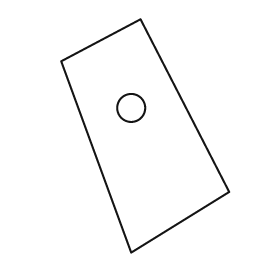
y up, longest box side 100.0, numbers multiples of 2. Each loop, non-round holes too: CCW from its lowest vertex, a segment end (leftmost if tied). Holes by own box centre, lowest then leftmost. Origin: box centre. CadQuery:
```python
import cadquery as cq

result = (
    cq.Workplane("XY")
    .moveTo(-6.0, -50.0)
    .lineTo(36.0, -24.0)
    .lineTo(-2.0, 50.0)
    .lineTo(-36.0, 32.0)
    .close()
    .moveTo(-6.0, 12.0)
    .circle(6.0)
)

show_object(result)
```